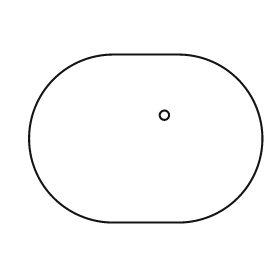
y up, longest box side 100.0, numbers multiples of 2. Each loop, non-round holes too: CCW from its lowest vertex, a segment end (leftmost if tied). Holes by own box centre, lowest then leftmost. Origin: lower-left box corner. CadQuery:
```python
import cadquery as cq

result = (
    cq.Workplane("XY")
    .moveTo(36.0, 0.0)
    .lineTo(64.0, 0.0)
    .threePointArc((100.0, 36.0), (64.0, 72.0))
    .lineTo(36.0, 72.0)
    .threePointArc((0.0, 36.0), (36.0, 0.0))
    .close()
    .moveTo(58.0, 46.0)
    .circle(2.0)
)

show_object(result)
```